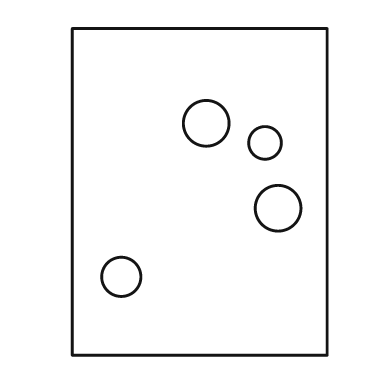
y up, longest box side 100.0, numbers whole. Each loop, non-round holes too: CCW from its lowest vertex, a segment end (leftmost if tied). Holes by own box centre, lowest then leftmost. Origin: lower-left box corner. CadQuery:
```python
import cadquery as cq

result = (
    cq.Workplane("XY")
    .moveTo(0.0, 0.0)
    .lineTo(78.0, 0.0)
    .lineTo(78.0, 100.0)
    .lineTo(0.0, 100.0)
    .close()
    .moveTo(15.0, 24.0)
    .circle(6.0)
    .moveTo(63.0, 45.0)
    .circle(7.0)
    .moveTo(59.0, 65.0)
    .circle(5.0)
    .moveTo(41.0, 71.0)
    .circle(7.0)
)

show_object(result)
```